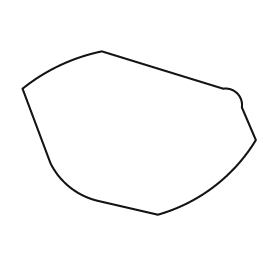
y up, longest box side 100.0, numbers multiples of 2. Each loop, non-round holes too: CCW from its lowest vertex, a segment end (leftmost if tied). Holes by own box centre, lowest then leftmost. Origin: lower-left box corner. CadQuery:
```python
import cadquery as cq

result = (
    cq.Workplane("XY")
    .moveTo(58.0, 0.0)
    .threePointArc((82.0, 12.0), (100.0, 32.0))
    .lineTo(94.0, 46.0)
    .threePointArc((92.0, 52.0), (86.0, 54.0))
    .lineTo(34.0, 70.0)
    .threePointArc((16.0, 64.0), (0.0, 54.0))
    .lineTo(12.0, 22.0)
    .threePointArc((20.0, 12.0), (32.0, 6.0))
    .close()
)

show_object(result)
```